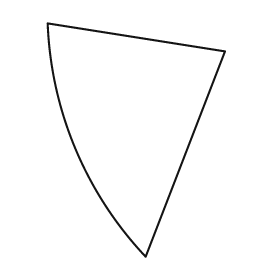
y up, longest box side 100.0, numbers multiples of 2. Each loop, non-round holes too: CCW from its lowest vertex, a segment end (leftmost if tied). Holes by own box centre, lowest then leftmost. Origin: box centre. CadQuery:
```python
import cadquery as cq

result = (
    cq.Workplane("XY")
    .moveTo(4.0, -50.0)
    .lineTo(38.0, 38.0)
    .lineTo(-38.0, 50.0)
    .threePointArc((-26.0, -4.0), (4.0, -50.0))
    .close()
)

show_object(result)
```